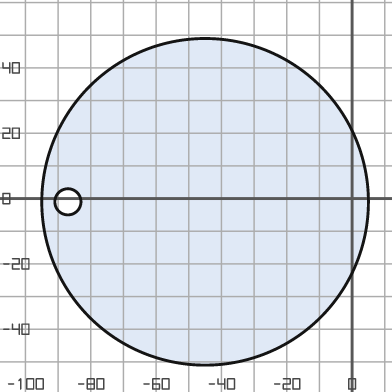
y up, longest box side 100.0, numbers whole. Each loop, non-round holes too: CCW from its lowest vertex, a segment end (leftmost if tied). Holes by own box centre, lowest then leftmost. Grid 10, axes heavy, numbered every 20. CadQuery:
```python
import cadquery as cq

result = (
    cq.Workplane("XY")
    .moveTo(-45.0, -1.0)
    .circle(50.0)
    .moveTo(-87.0, -1.0)
    .circle(4.0)
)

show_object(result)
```